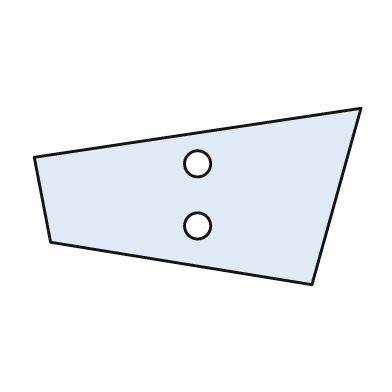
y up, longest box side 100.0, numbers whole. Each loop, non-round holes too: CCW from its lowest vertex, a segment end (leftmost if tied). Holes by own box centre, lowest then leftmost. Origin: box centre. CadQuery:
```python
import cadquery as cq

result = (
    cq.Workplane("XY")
    .moveTo(35.0, -27.0)
    .lineTo(50.0, 27.0)
    .lineTo(-50.0, 12.0)
    .lineTo(-45.0, -14.0)
    .close()
    .moveTo(0.0, -9.0)
    .circle(4.0)
    .moveTo(0.0, 10.0)
    .circle(4.0)
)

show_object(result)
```